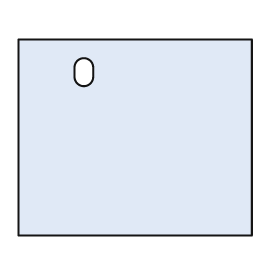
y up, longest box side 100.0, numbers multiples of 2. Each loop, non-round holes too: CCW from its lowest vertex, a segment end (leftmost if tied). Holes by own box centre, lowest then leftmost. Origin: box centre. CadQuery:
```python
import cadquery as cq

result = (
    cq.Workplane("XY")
    .moveTo(-50.0, -42.0)
    .lineTo(50.0, -42.0)
    .lineTo(50.0, 42.0)
    .lineTo(-50.0, 42.0)
    .close()
    .moveTo(-26.0, 26.0)
    .threePointArc((-22.0, 22.0), (-18.0, 26.0))
    .lineTo(-18.0, 30.0)
    .threePointArc((-22.0, 34.0), (-26.0, 30.0))
    .close()
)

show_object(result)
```